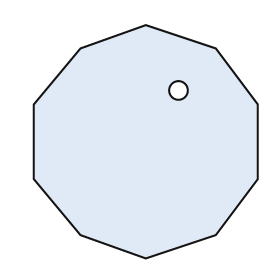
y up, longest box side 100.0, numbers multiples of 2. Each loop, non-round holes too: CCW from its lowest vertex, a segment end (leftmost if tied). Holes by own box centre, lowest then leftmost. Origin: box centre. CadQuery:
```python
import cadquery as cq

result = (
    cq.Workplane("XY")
    .moveTo(0.0, -50.0)
    .lineTo(30.0, -40.0)
    .lineTo(48.0, -16.0)
    .lineTo(48.0, 16.0)
    .lineTo(30.0, 40.0)
    .lineTo(0.0, 50.0)
    .lineTo(-28.0, 40.0)
    .lineTo(-48.0, 16.0)
    .lineTo(-48.0, -16.0)
    .lineTo(-28.0, -40.0)
    .close()
    .moveTo(14.0, 22.0)
    .circle(4.0)
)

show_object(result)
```